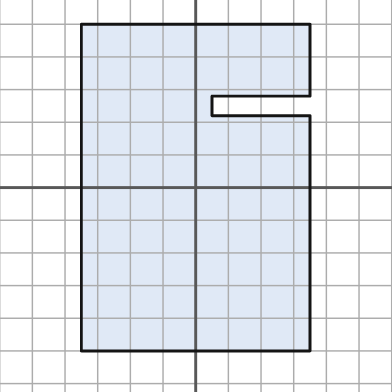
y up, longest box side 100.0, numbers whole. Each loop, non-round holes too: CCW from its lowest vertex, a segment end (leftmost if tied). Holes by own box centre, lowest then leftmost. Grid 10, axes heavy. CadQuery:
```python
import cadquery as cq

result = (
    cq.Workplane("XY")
    .moveTo(-35.0, -50.0)
    .lineTo(35.0, -50.0)
    .lineTo(35.0, 22.0)
    .lineTo(5.0, 22.0)
    .lineTo(5.0, 28.0)
    .lineTo(35.0, 28.0)
    .lineTo(35.0, 50.0)
    .lineTo(-35.0, 50.0)
    .close()
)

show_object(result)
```